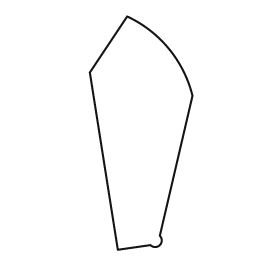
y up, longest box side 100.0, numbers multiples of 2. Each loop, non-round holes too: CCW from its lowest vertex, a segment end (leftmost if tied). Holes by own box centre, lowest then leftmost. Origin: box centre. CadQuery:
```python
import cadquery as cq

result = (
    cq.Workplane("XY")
    .moveTo(-10.0, -50.0)
    .lineTo(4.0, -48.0)
    .threePointArc((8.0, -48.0), (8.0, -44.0))
    .lineTo(22.0, 16.0)
    .threePointArc((12.0, 36.0), (-6.0, 50.0))
    .lineTo(-22.0, 26.0)
    .close()
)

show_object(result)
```